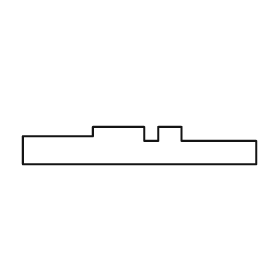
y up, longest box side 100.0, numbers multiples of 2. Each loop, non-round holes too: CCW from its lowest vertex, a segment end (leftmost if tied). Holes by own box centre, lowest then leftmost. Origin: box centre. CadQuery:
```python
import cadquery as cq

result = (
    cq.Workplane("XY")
    .moveTo(-50.0, -8.0)
    .lineTo(50.0, -8.0)
    .lineTo(50.0, 2.0)
    .lineTo(18.0, 2.0)
    .lineTo(18.0, 8.0)
    .lineTo(8.0, 8.0)
    .lineTo(8.0, 2.0)
    .lineTo(2.0, 2.0)
    .lineTo(2.0, 8.0)
    .lineTo(-20.0, 8.0)
    .lineTo(-20.0, 4.0)
    .lineTo(-50.0, 4.0)
    .close()
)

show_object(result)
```